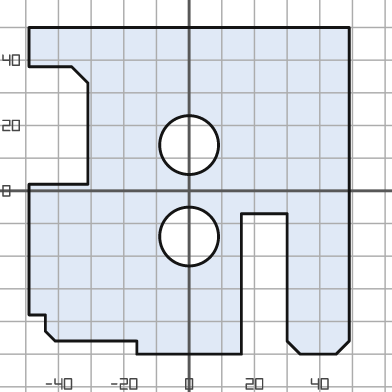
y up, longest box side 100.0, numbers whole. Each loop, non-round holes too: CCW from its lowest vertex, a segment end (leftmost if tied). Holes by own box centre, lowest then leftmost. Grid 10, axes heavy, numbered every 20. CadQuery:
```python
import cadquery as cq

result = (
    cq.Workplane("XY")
    .moveTo(-16.0, -50.0)
    .lineTo(16.0, -50.0)
    .lineTo(16.0, -7.0)
    .lineTo(30.0, -7.0)
    .lineTo(30.0, -46.0)
    .lineTo(34.0, -50.0)
    .lineTo(45.0, -50.0)
    .lineTo(49.0, -46.0)
    .lineTo(49.0, 50.0)
    .lineTo(-49.0, 50.0)
    .lineTo(-49.0, 38.0)
    .lineTo(-36.0, 38.0)
    .lineTo(-31.0, 33.0)
    .lineTo(-31.0, 2.0)
    .lineTo(-49.0, 2.0)
    .lineTo(-49.0, -38.0)
    .lineTo(-44.0, -38.0)
    .lineTo(-44.0, -43.0)
    .lineTo(-41.0, -46.0)
    .lineTo(-16.0, -46.0)
    .close()
    .moveTo(0.0, -14.0)
    .circle(9.0)
    .moveTo(0.0, 14.0)
    .circle(9.0)
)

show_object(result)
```